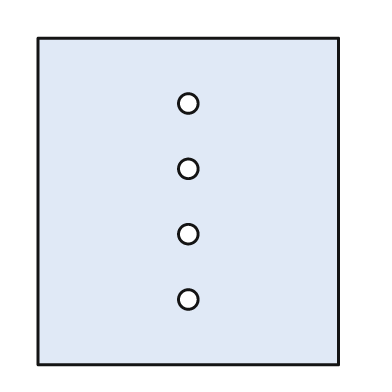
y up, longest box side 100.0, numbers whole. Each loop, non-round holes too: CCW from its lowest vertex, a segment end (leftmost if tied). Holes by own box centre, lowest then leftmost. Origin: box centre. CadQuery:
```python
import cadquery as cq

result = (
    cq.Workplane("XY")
    .moveTo(-46.0, -50.0)
    .lineTo(46.0, -50.0)
    .lineTo(46.0, 50.0)
    .lineTo(-46.0, 50.0)
    .close()
    .moveTo(0.0, -30.0)
    .circle(3.0)
    .moveTo(0.0, -10.0)
    .circle(3.0)
    .moveTo(0.0, 10.0)
    .circle(3.0)
    .moveTo(0.0, 30.0)
    .circle(3.0)
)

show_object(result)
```